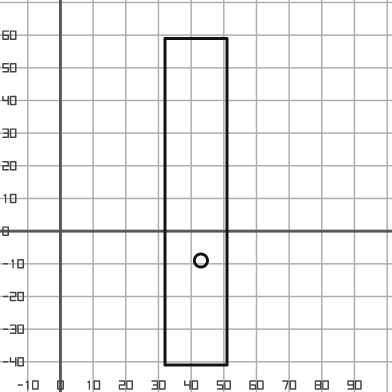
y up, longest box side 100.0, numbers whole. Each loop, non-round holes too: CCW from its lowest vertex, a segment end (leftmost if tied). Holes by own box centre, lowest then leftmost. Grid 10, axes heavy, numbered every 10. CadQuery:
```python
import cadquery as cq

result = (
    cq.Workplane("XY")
    .moveTo(32.0, -41.0)
    .lineTo(51.0, -41.0)
    .lineTo(51.0, 59.0)
    .lineTo(32.0, 59.0)
    .close()
    .moveTo(43.0, -9.0)
    .circle(2.0)
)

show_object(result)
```